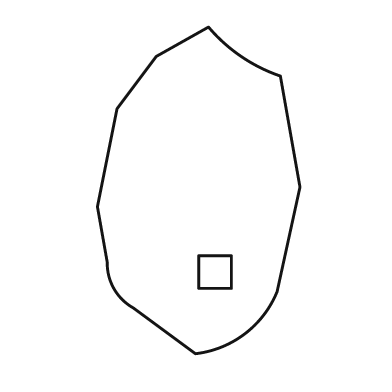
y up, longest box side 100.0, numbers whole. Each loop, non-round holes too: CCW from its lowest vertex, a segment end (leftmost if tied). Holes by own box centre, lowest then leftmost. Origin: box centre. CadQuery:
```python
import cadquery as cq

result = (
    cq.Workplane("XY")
    .moveTo(-1.0, -50.0)
    .threePointArc((14.0, -44.0), (24.0, -31.0))
    .lineTo(31.0, 1.0)
    .lineTo(25.0, 35.0)
    .threePointArc((13.0, 41.0), (3.0, 50.0))
    .lineTo(-13.0, 41.0)
    .lineTo(-25.0, 25.0)
    .lineTo(-31.0, -5.0)
    .lineTo(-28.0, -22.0)
    .threePointArc((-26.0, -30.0), (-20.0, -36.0))
    .close()
    .moveTo(0.0, -30.0)
    .lineTo(10.0, -30.0)
    .lineTo(10.0, -20.0)
    .lineTo(0.0, -20.0)
    .close()
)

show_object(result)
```